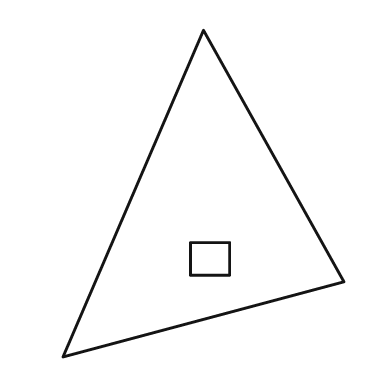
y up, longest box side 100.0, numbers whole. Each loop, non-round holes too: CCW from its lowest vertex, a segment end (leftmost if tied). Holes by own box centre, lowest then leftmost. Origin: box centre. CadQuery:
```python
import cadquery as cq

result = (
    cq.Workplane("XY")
    .moveTo(-43.0, -50.0)
    .lineTo(43.0, -27.0)
    .lineTo(0.0, 50.0)
    .close()
    .moveTo(-4.0, -25.0)
    .lineTo(8.0, -25.0)
    .lineTo(8.0, -15.0)
    .lineTo(-4.0, -15.0)
    .close()
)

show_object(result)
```